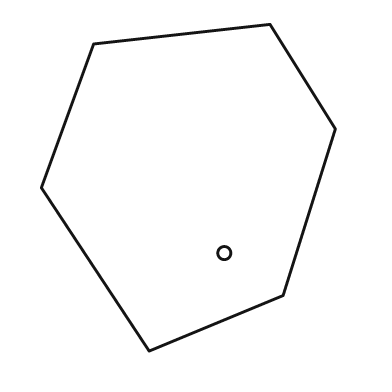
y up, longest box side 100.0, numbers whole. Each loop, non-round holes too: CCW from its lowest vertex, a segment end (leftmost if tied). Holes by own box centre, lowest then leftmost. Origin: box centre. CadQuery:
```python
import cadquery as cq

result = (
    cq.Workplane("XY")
    .moveTo(-12.0, -50.0)
    .lineTo(29.0, -33.0)
    .lineTo(45.0, 18.0)
    .lineTo(25.0, 50.0)
    .lineTo(-29.0, 44.0)
    .lineTo(-45.0, 0.0)
    .close()
    .moveTo(11.0, -20.0)
    .circle(2.0)
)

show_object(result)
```